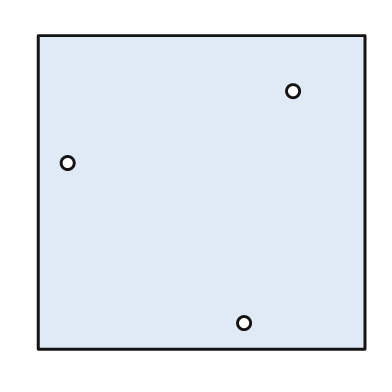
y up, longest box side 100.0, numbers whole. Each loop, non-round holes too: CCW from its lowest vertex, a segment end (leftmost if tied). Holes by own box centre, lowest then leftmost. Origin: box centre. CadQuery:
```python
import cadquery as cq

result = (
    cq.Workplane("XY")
    .moveTo(-50.0, -48.0)
    .lineTo(50.0, -48.0)
    .lineTo(50.0, 48.0)
    .lineTo(-50.0, 48.0)
    .close()
    .moveTo(13.0, -40.0)
    .circle(2.0)
    .moveTo(-41.0, 9.0)
    .circle(2.0)
    .moveTo(28.0, 31.0)
    .circle(2.0)
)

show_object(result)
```